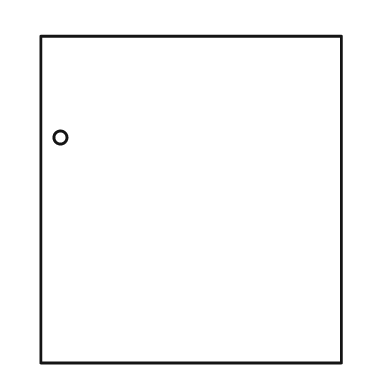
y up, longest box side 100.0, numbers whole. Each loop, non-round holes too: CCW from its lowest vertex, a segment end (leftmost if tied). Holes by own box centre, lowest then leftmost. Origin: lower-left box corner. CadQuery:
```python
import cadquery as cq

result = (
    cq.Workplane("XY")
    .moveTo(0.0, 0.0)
    .lineTo(92.0, 0.0)
    .lineTo(92.0, 100.0)
    .lineTo(0.0, 100.0)
    .close()
    .moveTo(6.0, 69.0)
    .circle(2.0)
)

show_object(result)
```